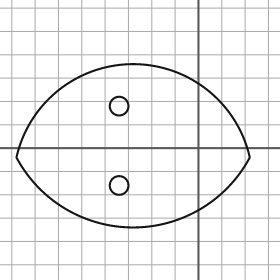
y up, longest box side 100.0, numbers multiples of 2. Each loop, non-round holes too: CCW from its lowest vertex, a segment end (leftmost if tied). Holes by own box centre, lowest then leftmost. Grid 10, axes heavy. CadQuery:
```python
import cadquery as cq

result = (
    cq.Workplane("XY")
    .moveTo(-78.0, -4.0)
    .threePointArc((-28.0, -34.0), (22.0, -4.0))
    .threePointArc((-28.0, 36.0), (-78.0, -4.0))
    .close()
    .moveTo(-34.0, -16.0)
    .circle(4.0)
    .moveTo(-34.0, 18.0)
    .circle(4.0)
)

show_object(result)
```